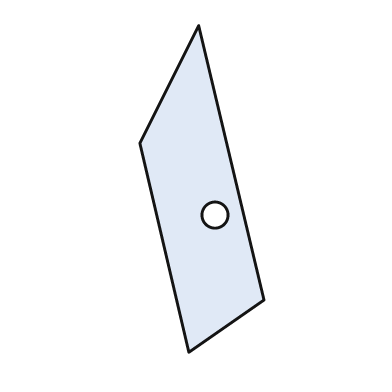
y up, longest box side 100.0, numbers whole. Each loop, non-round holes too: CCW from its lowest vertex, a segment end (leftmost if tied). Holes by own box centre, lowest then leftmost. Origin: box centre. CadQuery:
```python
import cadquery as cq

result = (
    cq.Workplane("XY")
    .moveTo(-4.0, -50.0)
    .lineTo(19.0, -34.0)
    .lineTo(-1.0, 50.0)
    .lineTo(-19.0, 14.0)
    .close()
    .moveTo(4.0, -8.0)
    .circle(4.0)
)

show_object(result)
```